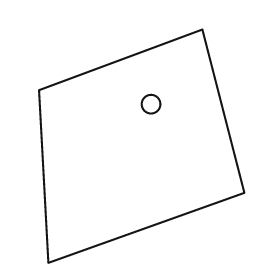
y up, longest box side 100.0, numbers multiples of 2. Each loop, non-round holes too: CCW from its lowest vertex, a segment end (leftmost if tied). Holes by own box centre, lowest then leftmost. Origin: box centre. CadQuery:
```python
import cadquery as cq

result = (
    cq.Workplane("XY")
    .moveTo(-40.0, -50.0)
    .lineTo(44.0, -20.0)
    .lineTo(26.0, 50.0)
    .lineTo(-44.0, 24.0)
    .close()
    .moveTo(4.0, 18.0)
    .circle(4.0)
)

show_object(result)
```